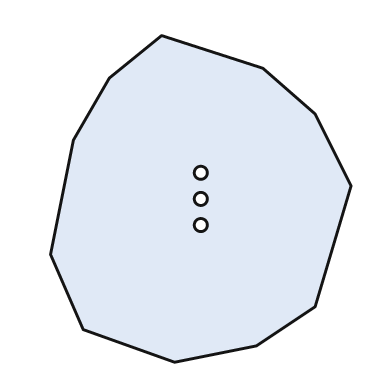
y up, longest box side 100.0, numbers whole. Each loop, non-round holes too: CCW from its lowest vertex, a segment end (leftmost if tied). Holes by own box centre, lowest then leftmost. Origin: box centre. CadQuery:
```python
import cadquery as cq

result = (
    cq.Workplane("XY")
    .moveTo(-8.0, -50.0)
    .lineTo(17.0, -45.0)
    .lineTo(35.0, -33.0)
    .lineTo(46.0, 4.0)
    .lineTo(35.0, 26.0)
    .lineTo(19.0, 40.0)
    .lineTo(-12.0, 50.0)
    .lineTo(-28.0, 37.0)
    .lineTo(-39.0, 18.0)
    .lineTo(-46.0, -17.0)
    .lineTo(-36.0, -40.0)
    .close()
    .moveTo(0.0, -8.0)
    .circle(2.0)
    .moveTo(0.0, 0.0)
    .circle(2.0)
    .moveTo(0.0, 8.0)
    .circle(2.0)
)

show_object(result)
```